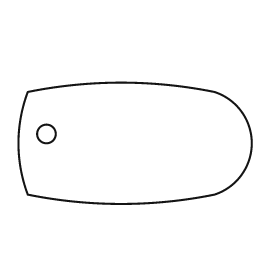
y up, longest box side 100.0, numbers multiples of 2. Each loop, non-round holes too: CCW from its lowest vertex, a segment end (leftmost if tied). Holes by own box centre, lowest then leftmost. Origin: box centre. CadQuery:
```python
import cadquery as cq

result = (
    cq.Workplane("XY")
    .moveTo(-46.0, -22.0)
    .threePointArc((-6.0, -26.0), (34.0, -22.0))
    .threePointArc((50.0, 0.0), (34.0, 22.0))
    .threePointArc((-6.0, 26.0), (-46.0, 22.0))
    .threePointArc((-50.0, 0.0), (-46.0, -22.0))
    .close()
    .moveTo(-38.0, 4.0)
    .circle(4.0)
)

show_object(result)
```